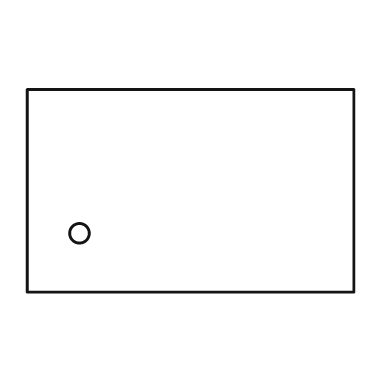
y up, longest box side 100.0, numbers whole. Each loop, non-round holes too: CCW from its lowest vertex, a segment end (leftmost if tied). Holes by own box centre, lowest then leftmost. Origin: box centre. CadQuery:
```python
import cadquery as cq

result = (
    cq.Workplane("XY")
    .moveTo(-50.0, -31.0)
    .lineTo(50.0, -31.0)
    .lineTo(50.0, 31.0)
    .lineTo(-50.0, 31.0)
    .close()
    .moveTo(-34.0, -13.0)
    .circle(3.0)
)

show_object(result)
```